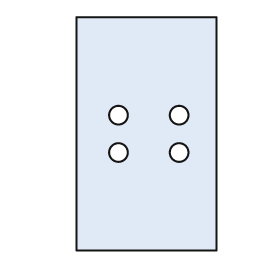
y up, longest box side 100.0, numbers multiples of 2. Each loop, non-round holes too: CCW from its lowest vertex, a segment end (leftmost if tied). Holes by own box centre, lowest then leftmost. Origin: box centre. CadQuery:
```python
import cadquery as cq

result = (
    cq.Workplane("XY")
    .moveTo(-30.0, -50.0)
    .lineTo(30.0, -50.0)
    .lineTo(30.0, 50.0)
    .lineTo(-30.0, 50.0)
    .close()
    .moveTo(-12.0, -8.0)
    .circle(4.0)
    .moveTo(14.0, -8.0)
    .circle(4.0)
    .moveTo(-12.0, 8.0)
    .circle(4.0)
    .moveTo(14.0, 8.0)
    .circle(4.0)
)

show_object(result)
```